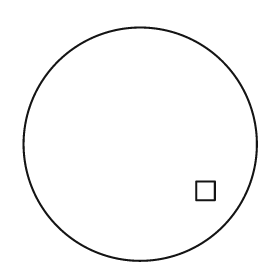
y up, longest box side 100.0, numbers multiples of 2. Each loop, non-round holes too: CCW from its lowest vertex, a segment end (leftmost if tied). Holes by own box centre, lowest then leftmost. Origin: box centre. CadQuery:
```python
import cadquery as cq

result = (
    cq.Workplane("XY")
    .moveTo(0.0, 0.0)
    .circle(50.0)
    .moveTo(24.0, -24.0)
    .lineTo(32.0, -24.0)
    .lineTo(32.0, -16.0)
    .lineTo(24.0, -16.0)
    .close()
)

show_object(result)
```